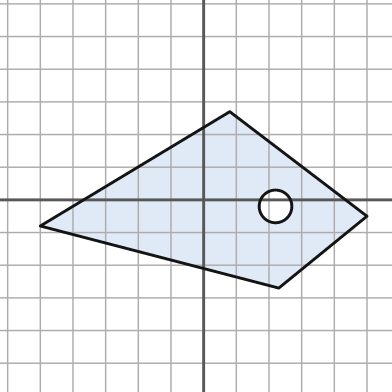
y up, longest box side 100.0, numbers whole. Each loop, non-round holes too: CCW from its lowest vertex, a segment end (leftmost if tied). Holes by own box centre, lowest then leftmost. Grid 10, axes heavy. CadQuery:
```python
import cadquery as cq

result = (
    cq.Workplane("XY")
    .moveTo(23.0, -27.0)
    .lineTo(50.0, -5.0)
    .lineTo(8.0, 27.0)
    .lineTo(-50.0, -8.0)
    .close()
    .moveTo(22.0, -2.0)
    .circle(5.0)
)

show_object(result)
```